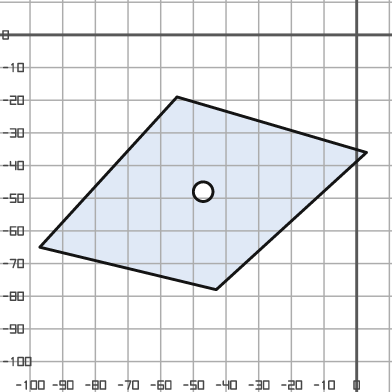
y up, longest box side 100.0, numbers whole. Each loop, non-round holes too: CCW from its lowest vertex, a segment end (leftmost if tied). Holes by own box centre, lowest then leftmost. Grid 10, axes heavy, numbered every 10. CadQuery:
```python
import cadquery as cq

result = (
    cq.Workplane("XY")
    .moveTo(-43.0, -78.0)
    .lineTo(3.0, -36.0)
    .lineTo(-55.0, -19.0)
    .lineTo(-97.0, -65.0)
    .close()
    .moveTo(-47.0, -48.0)
    .circle(3.0)
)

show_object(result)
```